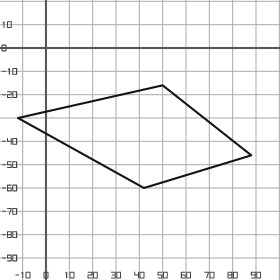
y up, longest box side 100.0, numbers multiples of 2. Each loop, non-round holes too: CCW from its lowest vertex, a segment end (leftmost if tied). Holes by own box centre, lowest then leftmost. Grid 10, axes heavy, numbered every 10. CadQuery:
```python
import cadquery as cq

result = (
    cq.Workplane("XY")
    .moveTo(42.0, -60.0)
    .lineTo(88.0, -46.0)
    .lineTo(50.0, -16.0)
    .lineTo(-12.0, -30.0)
    .close()
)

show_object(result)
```